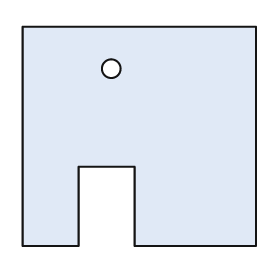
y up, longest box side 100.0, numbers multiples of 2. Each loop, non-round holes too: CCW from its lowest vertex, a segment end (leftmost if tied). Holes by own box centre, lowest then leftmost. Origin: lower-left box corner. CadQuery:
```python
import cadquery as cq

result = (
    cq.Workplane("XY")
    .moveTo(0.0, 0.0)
    .lineTo(24.0, 0.0)
    .lineTo(24.0, 34.0)
    .lineTo(48.0, 34.0)
    .lineTo(48.0, 0.0)
    .lineTo(100.0, 0.0)
    .lineTo(100.0, 94.0)
    .lineTo(0.0, 94.0)
    .close()
    .moveTo(38.0, 76.0)
    .circle(4.0)
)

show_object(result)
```